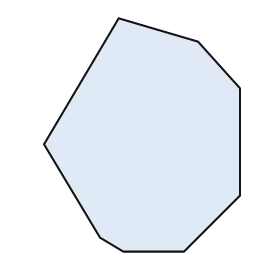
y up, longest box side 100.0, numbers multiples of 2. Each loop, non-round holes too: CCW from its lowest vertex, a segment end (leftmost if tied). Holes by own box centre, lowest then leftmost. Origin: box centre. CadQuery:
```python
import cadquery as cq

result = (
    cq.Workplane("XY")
    .moveTo(-8.0, -50.0)
    .lineTo(18.0, -50.0)
    .lineTo(42.0, -26.0)
    .lineTo(42.0, 20.0)
    .lineTo(24.0, 40.0)
    .lineTo(-10.0, 50.0)
    .lineTo(-42.0, -4.0)
    .lineTo(-18.0, -44.0)
    .close()
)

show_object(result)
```